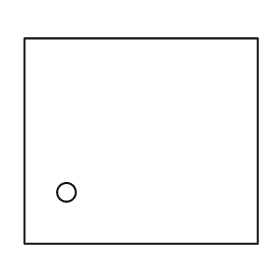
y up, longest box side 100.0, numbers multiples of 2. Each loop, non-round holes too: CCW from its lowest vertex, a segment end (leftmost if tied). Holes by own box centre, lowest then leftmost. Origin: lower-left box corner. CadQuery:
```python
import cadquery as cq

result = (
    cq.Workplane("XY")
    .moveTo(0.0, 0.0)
    .lineTo(100.0, 0.0)
    .lineTo(100.0, 88.0)
    .lineTo(0.0, 88.0)
    .close()
    .moveTo(18.0, 22.0)
    .circle(4.0)
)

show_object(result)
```